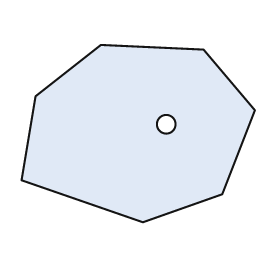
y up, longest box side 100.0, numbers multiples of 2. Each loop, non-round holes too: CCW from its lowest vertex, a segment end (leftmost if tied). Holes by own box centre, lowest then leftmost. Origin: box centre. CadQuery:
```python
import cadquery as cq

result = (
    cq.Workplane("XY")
    .moveTo(2.0, -38.0)
    .lineTo(36.0, -26.0)
    .lineTo(50.0, 10.0)
    .lineTo(28.0, 36.0)
    .lineTo(-16.0, 38.0)
    .lineTo(-44.0, 16.0)
    .lineTo(-50.0, -20.0)
    .close()
    .moveTo(12.0, 4.0)
    .circle(4.0)
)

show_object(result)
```